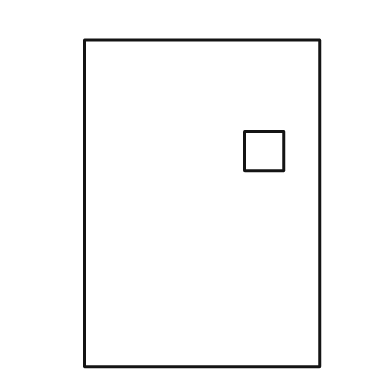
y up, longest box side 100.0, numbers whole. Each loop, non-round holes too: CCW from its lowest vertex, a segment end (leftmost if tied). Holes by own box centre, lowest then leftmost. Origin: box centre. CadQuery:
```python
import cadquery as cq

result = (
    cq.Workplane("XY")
    .moveTo(-36.0, -50.0)
    .lineTo(36.0, -50.0)
    .lineTo(36.0, 50.0)
    .lineTo(-36.0, 50.0)
    .close()
    .moveTo(13.0, 10.0)
    .lineTo(25.0, 10.0)
    .lineTo(25.0, 22.0)
    .lineTo(13.0, 22.0)
    .close()
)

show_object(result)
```